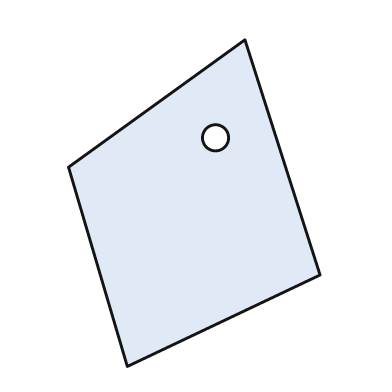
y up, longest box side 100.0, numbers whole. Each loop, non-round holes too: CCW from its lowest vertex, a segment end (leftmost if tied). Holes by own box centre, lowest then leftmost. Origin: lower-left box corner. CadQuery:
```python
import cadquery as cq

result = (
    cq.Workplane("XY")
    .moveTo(18.0, 0.0)
    .lineTo(77.0, 28.0)
    .lineTo(54.0, 100.0)
    .lineTo(0.0, 61.0)
    .close()
    .moveTo(45.0, 70.0)
    .circle(4.0)
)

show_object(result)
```